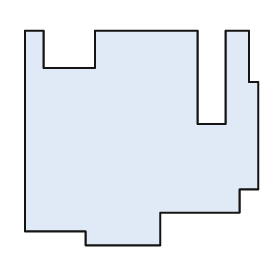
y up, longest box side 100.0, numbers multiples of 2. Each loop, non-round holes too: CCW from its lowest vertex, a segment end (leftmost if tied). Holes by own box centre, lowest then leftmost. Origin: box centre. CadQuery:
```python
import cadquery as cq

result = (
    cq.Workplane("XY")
    .moveTo(-24.0, -46.0)
    .lineTo(8.0, -46.0)
    .lineTo(8.0, -32.0)
    .lineTo(42.0, -32.0)
    .lineTo(42.0, -22.0)
    .lineTo(50.0, -22.0)
    .lineTo(50.0, 24.0)
    .lineTo(46.0, 24.0)
    .lineTo(46.0, 46.0)
    .lineTo(36.0, 46.0)
    .lineTo(36.0, 6.0)
    .lineTo(24.0, 6.0)
    .lineTo(24.0, 46.0)
    .lineTo(-20.0, 46.0)
    .lineTo(-20.0, 30.0)
    .lineTo(-42.0, 30.0)
    .lineTo(-42.0, 46.0)
    .lineTo(-50.0, 46.0)
    .lineTo(-50.0, -40.0)
    .lineTo(-24.0, -40.0)
    .close()
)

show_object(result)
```